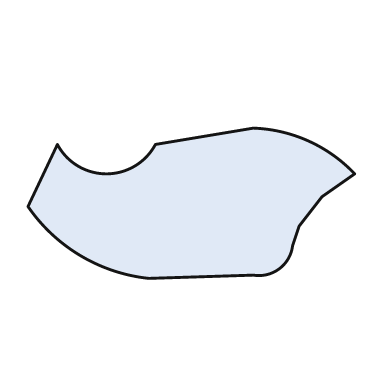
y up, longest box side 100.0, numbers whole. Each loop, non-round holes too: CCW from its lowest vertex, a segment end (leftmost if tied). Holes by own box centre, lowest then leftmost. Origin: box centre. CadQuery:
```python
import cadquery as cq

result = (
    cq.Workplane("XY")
    .moveTo(-13.0, -23.0)
    .lineTo(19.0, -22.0)
    .threePointArc((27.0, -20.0), (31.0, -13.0))
    .lineTo(33.0, -7.0)
    .lineTo(40.0, 2.0)
    .lineTo(50.0, 9.0)
    .threePointArc((36.0, 19.0), (19.0, 23.0))
    .lineTo(-11.0, 18.0)
    .threePointArc((-26.0, 9.0), (-41.0, 18.0))
    .lineTo(-50.0, -1.0)
    .threePointArc((-34.0, -16.0), (-13.0, -23.0))
    .close()
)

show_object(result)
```